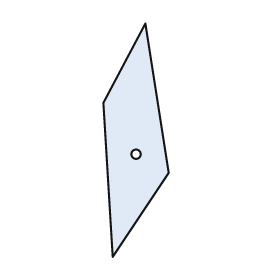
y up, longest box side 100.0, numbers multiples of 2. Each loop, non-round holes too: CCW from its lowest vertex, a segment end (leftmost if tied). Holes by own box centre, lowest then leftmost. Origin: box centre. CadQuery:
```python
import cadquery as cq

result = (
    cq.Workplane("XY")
    .moveTo(-10.0, -50.0)
    .lineTo(14.0, -14.0)
    .lineTo(4.0, 50.0)
    .lineTo(-14.0, 16.0)
    .close()
    .moveTo(0.0, -6.0)
    .circle(2.0)
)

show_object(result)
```